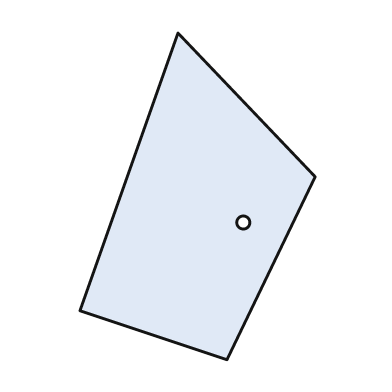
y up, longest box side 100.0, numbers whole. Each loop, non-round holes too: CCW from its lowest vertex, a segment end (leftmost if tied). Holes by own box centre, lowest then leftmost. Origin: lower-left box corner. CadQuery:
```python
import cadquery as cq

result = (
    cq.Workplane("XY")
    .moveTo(45.0, 0.0)
    .lineTo(72.0, 56.0)
    .lineTo(30.0, 100.0)
    .lineTo(0.0, 15.0)
    .close()
    .moveTo(50.0, 42.0)
    .circle(2.0)
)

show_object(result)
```